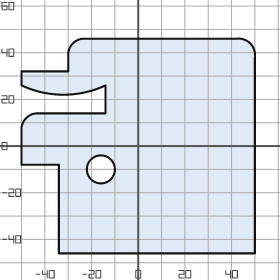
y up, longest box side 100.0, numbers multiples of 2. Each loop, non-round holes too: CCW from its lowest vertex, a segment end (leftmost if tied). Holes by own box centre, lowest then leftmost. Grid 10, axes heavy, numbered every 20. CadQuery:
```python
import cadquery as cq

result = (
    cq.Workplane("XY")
    .moveTo(-34.0, -46.0)
    .lineTo(50.0, -46.0)
    .lineTo(50.0, 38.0)
    .threePointArc((48.0, 44.0), (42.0, 46.0))
    .lineTo(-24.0, 46.0)
    .threePointArc((-28.0, 44.0), (-30.0, 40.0))
    .lineTo(-30.0, 32.0)
    .lineTo(-50.0, 32.0)
    .lineTo(-50.0, 26.0)
    .threePointArc((-32.0, 22.0), (-14.0, 26.0))
    .lineTo(-14.0, 14.0)
    .lineTo(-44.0, 14.0)
    .threePointArc((-48.0, 12.0), (-50.0, 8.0))
    .lineTo(-50.0, -8.0)
    .lineTo(-34.0, -8.0)
    .close()
    .moveTo(-16.0, -10.0)
    .circle(6.0)
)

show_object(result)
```